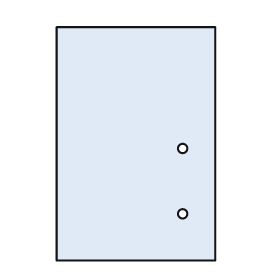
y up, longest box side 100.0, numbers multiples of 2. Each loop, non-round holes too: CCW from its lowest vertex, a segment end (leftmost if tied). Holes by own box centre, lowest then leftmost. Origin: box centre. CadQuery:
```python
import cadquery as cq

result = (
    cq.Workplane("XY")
    .moveTo(-34.0, -50.0)
    .lineTo(34.0, -50.0)
    .lineTo(34.0, 50.0)
    .lineTo(-34.0, 50.0)
    .close()
    .moveTo(20.0, -30.0)
    .circle(2.0)
    .moveTo(20.0, -2.0)
    .circle(2.0)
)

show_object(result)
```